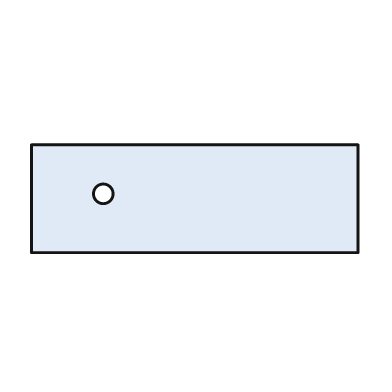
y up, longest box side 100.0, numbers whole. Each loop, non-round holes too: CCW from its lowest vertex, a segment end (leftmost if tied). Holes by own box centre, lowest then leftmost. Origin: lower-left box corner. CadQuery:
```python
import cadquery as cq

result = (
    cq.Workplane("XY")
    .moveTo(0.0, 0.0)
    .lineTo(100.0, 0.0)
    .lineTo(100.0, 33.0)
    .lineTo(0.0, 33.0)
    .close()
    .moveTo(22.0, 18.0)
    .circle(3.0)
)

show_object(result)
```